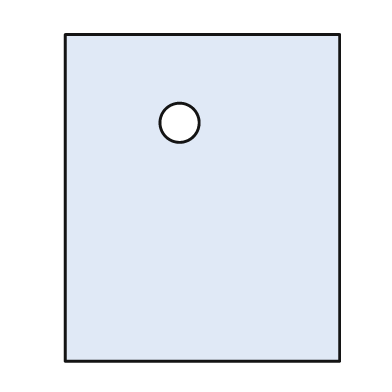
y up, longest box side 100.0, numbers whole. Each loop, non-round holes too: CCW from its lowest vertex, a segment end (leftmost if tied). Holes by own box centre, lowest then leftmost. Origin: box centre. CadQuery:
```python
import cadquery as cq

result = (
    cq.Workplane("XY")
    .moveTo(-42.0, -50.0)
    .lineTo(42.0, -50.0)
    .lineTo(42.0, 50.0)
    .lineTo(-42.0, 50.0)
    .close()
    .moveTo(-7.0, 23.0)
    .circle(6.0)
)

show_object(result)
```